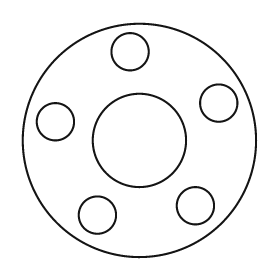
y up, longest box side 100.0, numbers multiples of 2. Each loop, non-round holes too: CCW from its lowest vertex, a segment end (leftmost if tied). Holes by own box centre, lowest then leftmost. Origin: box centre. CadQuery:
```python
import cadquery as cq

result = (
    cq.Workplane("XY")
    .moveTo(0.0, 0.0)
    .circle(50.0)
    .moveTo(-18.0, -32.0)
    .circle(8.0)
    .moveTo(24.0, -28.0)
    .circle(8.0)
    .moveTo(0.0, 0.0)
    .circle(20.0)
    .moveTo(-36.0, 8.0)
    .circle(8.0)
    .moveTo(34.0, 16.0)
    .circle(8.0)
    .moveTo(-4.0, 38.0)
    .circle(8.0)
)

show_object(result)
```